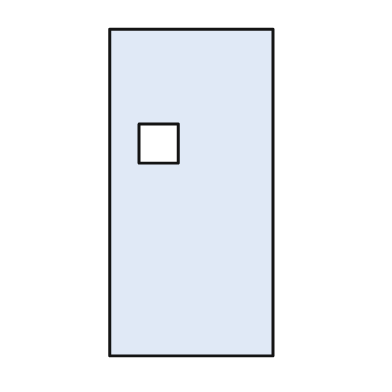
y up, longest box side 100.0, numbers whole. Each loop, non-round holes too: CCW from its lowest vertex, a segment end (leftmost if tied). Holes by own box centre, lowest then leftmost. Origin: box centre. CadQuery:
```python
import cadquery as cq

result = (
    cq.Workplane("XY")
    .moveTo(-25.0, -50.0)
    .lineTo(25.0, -50.0)
    .lineTo(25.0, 50.0)
    .lineTo(-25.0, 50.0)
    .close()
    .moveTo(-16.0, 9.0)
    .lineTo(-4.0, 9.0)
    .lineTo(-4.0, 21.0)
    .lineTo(-16.0, 21.0)
    .close()
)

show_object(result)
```